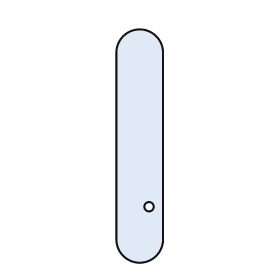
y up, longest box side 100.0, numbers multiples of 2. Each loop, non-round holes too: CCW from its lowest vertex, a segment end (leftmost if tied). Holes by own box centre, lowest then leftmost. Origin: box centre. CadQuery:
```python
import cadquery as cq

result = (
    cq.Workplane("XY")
    .moveTo(-10.0, -40.0)
    .threePointArc((0.0, -50.0), (10.0, -40.0))
    .lineTo(10.0, 40.0)
    .threePointArc((0.0, 50.0), (-10.0, 40.0))
    .close()
    .moveTo(4.0, -26.0)
    .circle(2.0)
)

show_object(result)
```